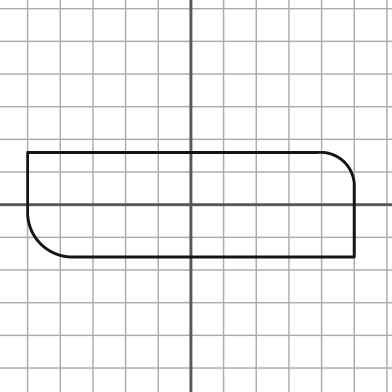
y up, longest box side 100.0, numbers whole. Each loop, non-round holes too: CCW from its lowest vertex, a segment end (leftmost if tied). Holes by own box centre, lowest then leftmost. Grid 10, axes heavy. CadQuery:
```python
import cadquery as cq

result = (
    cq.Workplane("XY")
    .moveTo(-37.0, -16.0)
    .lineTo(50.0, -16.0)
    .lineTo(50.0, 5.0)
    .threePointArc((47.0, 13.0), (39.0, 16.0))
    .lineTo(-50.0, 16.0)
    .lineTo(-50.0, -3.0)
    .threePointArc((-46.0, -12.0), (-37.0, -16.0))
    .close()
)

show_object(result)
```